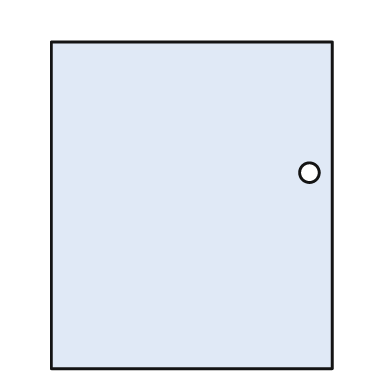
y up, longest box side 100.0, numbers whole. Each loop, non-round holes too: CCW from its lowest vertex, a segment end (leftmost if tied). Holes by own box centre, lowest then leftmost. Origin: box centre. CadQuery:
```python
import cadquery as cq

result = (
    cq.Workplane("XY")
    .moveTo(-43.0, -50.0)
    .lineTo(43.0, -50.0)
    .lineTo(43.0, 50.0)
    .lineTo(-43.0, 50.0)
    .close()
    .moveTo(36.0, 10.0)
    .circle(3.0)
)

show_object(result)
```